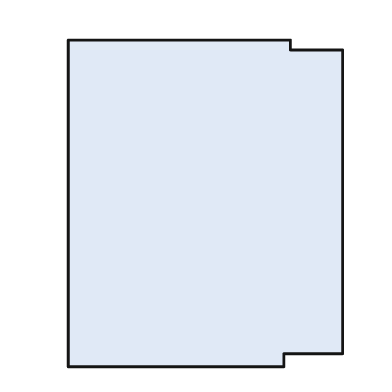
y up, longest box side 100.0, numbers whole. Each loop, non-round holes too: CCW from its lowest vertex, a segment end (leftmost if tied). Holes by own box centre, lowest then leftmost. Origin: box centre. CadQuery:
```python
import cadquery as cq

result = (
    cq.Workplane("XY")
    .moveTo(-42.0, -50.0)
    .lineTo(24.0, -50.0)
    .lineTo(24.0, -46.0)
    .lineTo(42.0, -46.0)
    .lineTo(42.0, 47.0)
    .lineTo(26.0, 47.0)
    .lineTo(26.0, 50.0)
    .lineTo(-42.0, 50.0)
    .close()
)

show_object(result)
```